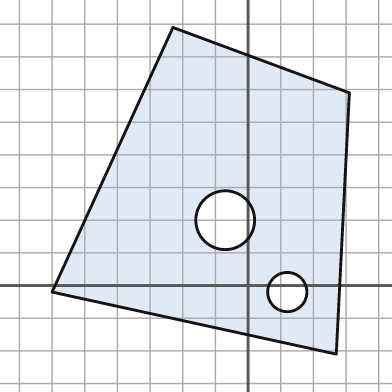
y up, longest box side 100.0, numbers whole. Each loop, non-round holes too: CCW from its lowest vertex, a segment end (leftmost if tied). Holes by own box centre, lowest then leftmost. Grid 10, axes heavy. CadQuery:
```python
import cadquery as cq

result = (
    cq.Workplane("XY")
    .moveTo(27.0, -21.0)
    .lineTo(31.0, 59.0)
    .lineTo(-23.0, 79.0)
    .lineTo(-60.0, -2.0)
    .close()
    .moveTo(12.0, -2.0)
    .circle(6.0)
    .moveTo(-7.0, 20.0)
    .circle(9.0)
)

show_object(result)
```